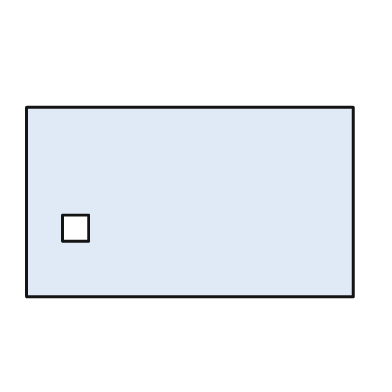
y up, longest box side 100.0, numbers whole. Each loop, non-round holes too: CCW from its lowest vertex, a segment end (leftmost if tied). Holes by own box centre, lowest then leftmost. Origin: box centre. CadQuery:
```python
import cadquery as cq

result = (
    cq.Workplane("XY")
    .moveTo(-50.0, -29.0)
    .lineTo(50.0, -29.0)
    .lineTo(50.0, 29.0)
    .lineTo(-50.0, 29.0)
    .close()
    .moveTo(-39.0, -12.0)
    .lineTo(-31.0, -12.0)
    .lineTo(-31.0, -4.0)
    .lineTo(-39.0, -4.0)
    .close()
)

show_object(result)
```